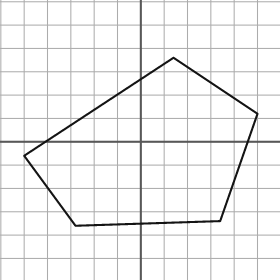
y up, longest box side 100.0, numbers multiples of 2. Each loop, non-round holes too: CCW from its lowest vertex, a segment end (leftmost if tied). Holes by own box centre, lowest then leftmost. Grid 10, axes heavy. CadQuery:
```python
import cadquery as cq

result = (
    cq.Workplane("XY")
    .moveTo(-28.0, -36.0)
    .lineTo(34.0, -34.0)
    .lineTo(50.0, 12.0)
    .lineTo(14.0, 36.0)
    .lineTo(-50.0, -6.0)
    .close()
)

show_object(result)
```